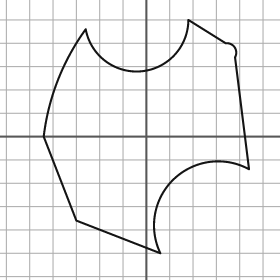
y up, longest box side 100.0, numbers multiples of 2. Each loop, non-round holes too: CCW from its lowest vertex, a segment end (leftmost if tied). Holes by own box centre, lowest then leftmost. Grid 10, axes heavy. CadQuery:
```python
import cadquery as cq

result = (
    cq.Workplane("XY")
    .moveTo(6.0, -50.0)
    .threePointArc((12.0, -18.0), (44.0, -14.0))
    .lineTo(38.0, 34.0)
    .threePointArc((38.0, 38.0), (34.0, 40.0))
    .lineTo(18.0, 50.0)
    .threePointArc((-2.0, 28.0), (-26.0, 46.0))
    .threePointArc((-38.0, 24.0), (-44.0, 0.0))
    .lineTo(-30.0, -36.0)
    .close()
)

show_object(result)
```